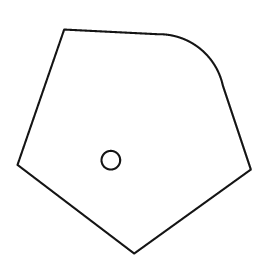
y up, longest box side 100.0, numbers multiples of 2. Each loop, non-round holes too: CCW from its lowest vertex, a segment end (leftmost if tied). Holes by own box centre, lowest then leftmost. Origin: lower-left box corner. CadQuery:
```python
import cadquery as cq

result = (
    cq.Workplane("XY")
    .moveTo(50.0, 0.0)
    .lineTo(100.0, 36.0)
    .lineTo(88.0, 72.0)
    .threePointArc((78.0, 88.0), (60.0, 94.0))
    .lineTo(20.0, 96.0)
    .lineTo(0.0, 38.0)
    .close()
    .moveTo(40.0, 40.0)
    .circle(4.0)
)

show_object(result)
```